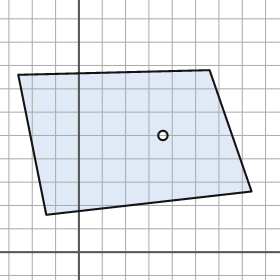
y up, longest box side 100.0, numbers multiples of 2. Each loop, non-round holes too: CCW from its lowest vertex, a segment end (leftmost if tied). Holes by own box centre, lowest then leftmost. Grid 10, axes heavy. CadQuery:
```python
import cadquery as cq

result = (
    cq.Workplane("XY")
    .moveTo(-14.0, 16.0)
    .lineTo(74.0, 26.0)
    .lineTo(56.0, 78.0)
    .lineTo(-26.0, 76.0)
    .close()
    .moveTo(36.0, 50.0)
    .circle(2.0)
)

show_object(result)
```